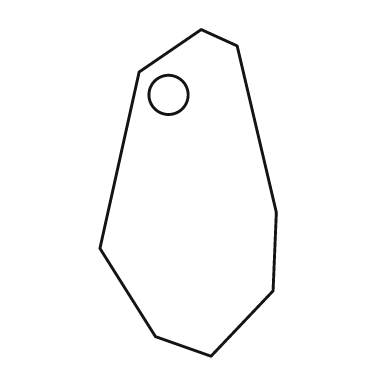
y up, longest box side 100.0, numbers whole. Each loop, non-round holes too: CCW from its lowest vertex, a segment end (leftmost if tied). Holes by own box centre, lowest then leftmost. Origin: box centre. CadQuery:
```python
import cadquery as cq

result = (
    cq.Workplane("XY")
    .moveTo(7.0, -50.0)
    .lineTo(26.0, -30.0)
    .lineTo(27.0, -6.0)
    .lineTo(15.0, 45.0)
    .lineTo(4.0, 50.0)
    .lineTo(-15.0, 37.0)
    .lineTo(-27.0, -17.0)
    .lineTo(-10.0, -44.0)
    .close()
    .moveTo(-6.0, 30.0)
    .circle(6.0)
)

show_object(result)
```